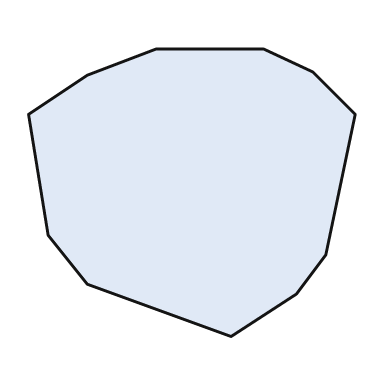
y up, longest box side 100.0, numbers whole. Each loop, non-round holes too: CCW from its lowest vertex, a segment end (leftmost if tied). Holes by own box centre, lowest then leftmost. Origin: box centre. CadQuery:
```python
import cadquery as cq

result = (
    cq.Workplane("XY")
    .moveTo(12.0, -44.0)
    .lineTo(32.0, -31.0)
    .lineTo(41.0, -19.0)
    .lineTo(50.0, 24.0)
    .lineTo(37.0, 37.0)
    .lineTo(22.0, 44.0)
    .lineTo(-11.0, 44.0)
    .lineTo(-32.0, 36.0)
    .lineTo(-50.0, 24.0)
    .lineTo(-44.0, -13.0)
    .lineTo(-32.0, -28.0)
    .close()
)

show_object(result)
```